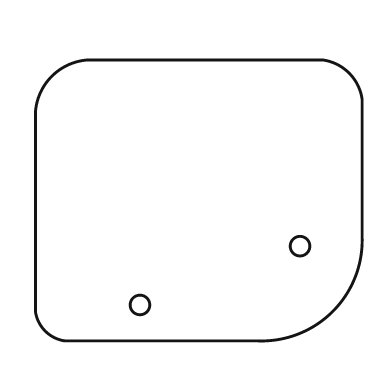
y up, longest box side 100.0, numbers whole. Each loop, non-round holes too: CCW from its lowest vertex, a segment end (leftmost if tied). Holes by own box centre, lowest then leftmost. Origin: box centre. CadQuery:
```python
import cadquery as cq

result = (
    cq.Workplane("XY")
    .moveTo(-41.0, -43.0)
    .lineTo(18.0, -43.0)
    .threePointArc((41.0, -34.0), (50.0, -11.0))
    .lineTo(50.0, 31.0)
    .threePointArc((46.0, 39.0), (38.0, 43.0))
    .lineTo(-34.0, 43.0)
    .threePointArc((-45.0, 38.0), (-50.0, 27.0))
    .lineTo(-50.0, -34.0)
    .threePointArc((-47.0, -40.0), (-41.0, -43.0))
    .close()
    .moveTo(-18.0, -32.0)
    .circle(3.0)
    .moveTo(31.0, -14.0)
    .circle(3.0)
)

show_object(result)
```